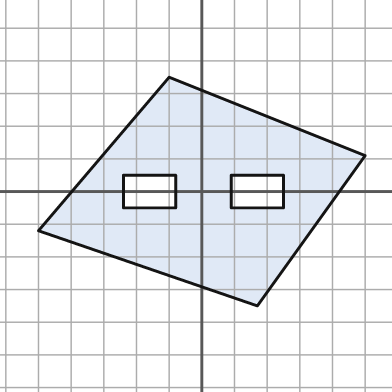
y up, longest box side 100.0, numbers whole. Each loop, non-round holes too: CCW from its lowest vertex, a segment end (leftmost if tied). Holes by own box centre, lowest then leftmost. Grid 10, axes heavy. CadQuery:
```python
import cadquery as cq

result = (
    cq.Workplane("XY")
    .moveTo(17.0, -35.0)
    .lineTo(50.0, 11.0)
    .lineTo(-10.0, 35.0)
    .lineTo(-50.0, -12.0)
    .close()
    .moveTo(-24.0, -5.0)
    .lineTo(-8.0, -5.0)
    .lineTo(-8.0, 5.0)
    .lineTo(-24.0, 5.0)
    .close()
    .moveTo(9.0, -5.0)
    .lineTo(25.0, -5.0)
    .lineTo(25.0, 5.0)
    .lineTo(9.0, 5.0)
    .close()
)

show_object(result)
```